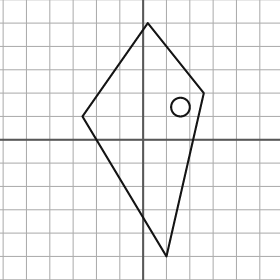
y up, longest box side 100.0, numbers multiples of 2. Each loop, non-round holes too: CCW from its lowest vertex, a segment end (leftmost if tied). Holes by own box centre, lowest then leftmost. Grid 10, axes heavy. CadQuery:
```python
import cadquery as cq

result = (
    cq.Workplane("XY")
    .moveTo(10.0, -50.0)
    .lineTo(26.0, 20.0)
    .lineTo(2.0, 50.0)
    .lineTo(-26.0, 10.0)
    .close()
    .moveTo(16.0, 14.0)
    .circle(4.0)
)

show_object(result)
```